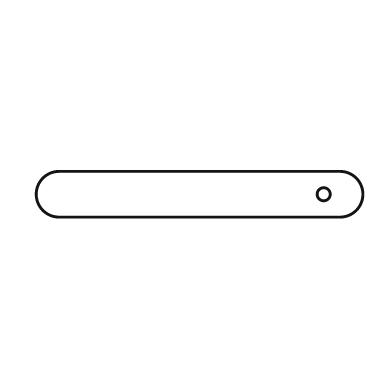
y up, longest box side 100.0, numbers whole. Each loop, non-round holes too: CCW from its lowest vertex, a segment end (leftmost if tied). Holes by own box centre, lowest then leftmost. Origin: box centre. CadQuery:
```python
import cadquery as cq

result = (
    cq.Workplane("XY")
    .moveTo(-43.0, -7.0)
    .lineTo(43.0, -7.0)
    .threePointArc((50.0, 0.0), (43.0, 7.0))
    .lineTo(-43.0, 7.0)
    .threePointArc((-50.0, 0.0), (-43.0, -7.0))
    .close()
    .moveTo(38.0, 0.0)
    .circle(2.0)
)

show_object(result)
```